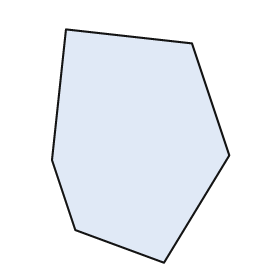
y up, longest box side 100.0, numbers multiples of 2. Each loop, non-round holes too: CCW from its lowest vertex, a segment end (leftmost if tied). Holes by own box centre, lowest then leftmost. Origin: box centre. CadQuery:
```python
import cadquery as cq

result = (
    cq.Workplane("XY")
    .moveTo(10.0, -50.0)
    .lineTo(38.0, -4.0)
    .lineTo(22.0, 44.0)
    .lineTo(-32.0, 50.0)
    .lineTo(-38.0, -6.0)
    .lineTo(-28.0, -36.0)
    .close()
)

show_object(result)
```